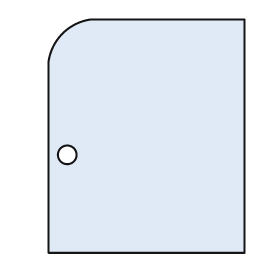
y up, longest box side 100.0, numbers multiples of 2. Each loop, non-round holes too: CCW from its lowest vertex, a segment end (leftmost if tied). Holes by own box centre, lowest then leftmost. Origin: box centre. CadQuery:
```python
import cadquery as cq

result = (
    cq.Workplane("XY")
    .moveTo(-42.0, -50.0)
    .lineTo(42.0, -50.0)
    .lineTo(42.0, 50.0)
    .lineTo(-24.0, 50.0)
    .threePointArc((-36.0, 44.0), (-42.0, 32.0))
    .close()
    .moveTo(-34.0, -8.0)
    .circle(4.0)
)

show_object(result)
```